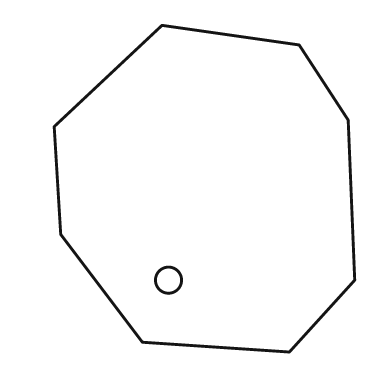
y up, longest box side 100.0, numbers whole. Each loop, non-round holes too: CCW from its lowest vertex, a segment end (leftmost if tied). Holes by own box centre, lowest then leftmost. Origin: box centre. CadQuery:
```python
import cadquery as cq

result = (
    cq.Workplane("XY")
    .moveTo(26.0, -50.0)
    .lineTo(46.0, -28.0)
    .lineTo(44.0, 21.0)
    .lineTo(29.0, 44.0)
    .lineTo(-13.0, 50.0)
    .lineTo(-46.0, 19.0)
    .lineTo(-44.0, -14.0)
    .lineTo(-19.0, -47.0)
    .close()
    .moveTo(-11.0, -28.0)
    .circle(4.0)
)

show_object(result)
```